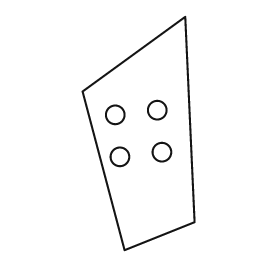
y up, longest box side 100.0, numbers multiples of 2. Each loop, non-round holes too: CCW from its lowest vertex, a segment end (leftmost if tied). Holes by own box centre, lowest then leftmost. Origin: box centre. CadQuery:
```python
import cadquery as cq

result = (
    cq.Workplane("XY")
    .moveTo(-6.0, -50.0)
    .lineTo(24.0, -38.0)
    .lineTo(20.0, 50.0)
    .lineTo(-24.0, 18.0)
    .close()
    .moveTo(-8.0, -10.0)
    .circle(4.0)
    .moveTo(10.0, -8.0)
    .circle(4.0)
    .moveTo(-10.0, 8.0)
    .circle(4.0)
    .moveTo(8.0, 10.0)
    .circle(4.0)
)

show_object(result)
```